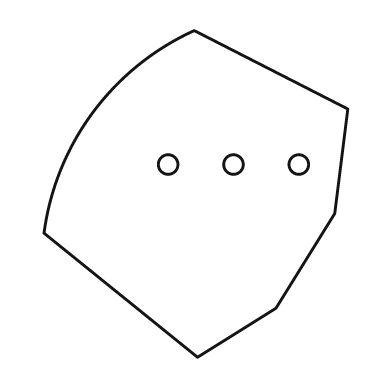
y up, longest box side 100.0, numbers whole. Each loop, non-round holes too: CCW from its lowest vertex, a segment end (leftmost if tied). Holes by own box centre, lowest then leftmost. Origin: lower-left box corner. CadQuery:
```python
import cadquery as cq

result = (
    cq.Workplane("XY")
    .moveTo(47.0, 0.0)
    .lineTo(71.0, 15.0)
    .lineTo(89.0, 44.0)
    .lineTo(93.0, 76.0)
    .lineTo(46.0, 100.0)
    .threePointArc((15.0, 75.0), (0.0, 38.0))
    .close()
    .moveTo(38.0, 59.0)
    .circle(3.0)
    .moveTo(58.0, 59.0)
    .circle(3.0)
    .moveTo(78.0, 59.0)
    .circle(3.0)
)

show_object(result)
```